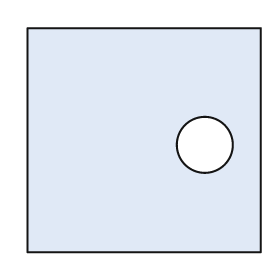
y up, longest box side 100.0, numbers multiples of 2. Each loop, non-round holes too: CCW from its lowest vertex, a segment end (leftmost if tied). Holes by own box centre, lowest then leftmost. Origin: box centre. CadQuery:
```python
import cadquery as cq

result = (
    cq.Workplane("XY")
    .moveTo(-50.0, -48.0)
    .lineTo(50.0, -48.0)
    .lineTo(50.0, 48.0)
    .lineTo(-50.0, 48.0)
    .close()
    .moveTo(26.0, -2.0)
    .circle(12.0)
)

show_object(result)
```